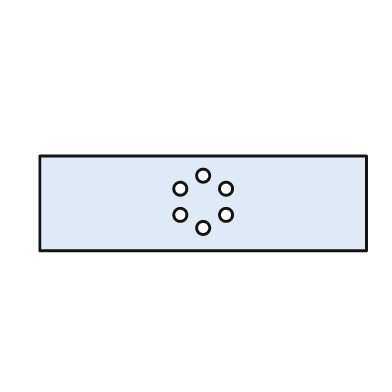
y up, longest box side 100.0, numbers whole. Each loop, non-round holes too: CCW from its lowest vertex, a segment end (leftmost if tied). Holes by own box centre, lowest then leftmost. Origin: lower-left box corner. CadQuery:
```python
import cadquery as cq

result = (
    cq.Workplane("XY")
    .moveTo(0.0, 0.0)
    .lineTo(100.0, 0.0)
    .lineTo(100.0, 29.0)
    .lineTo(0.0, 29.0)
    .close()
    .moveTo(50.0, 7.0)
    .circle(2.0)
    .moveTo(43.0, 11.0)
    .circle(2.0)
    .moveTo(57.0, 11.0)
    .circle(2.0)
    .moveTo(43.0, 19.0)
    .circle(2.0)
    .moveTo(57.0, 19.0)
    .circle(2.0)
    .moveTo(50.0, 23.0)
    .circle(2.0)
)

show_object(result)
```